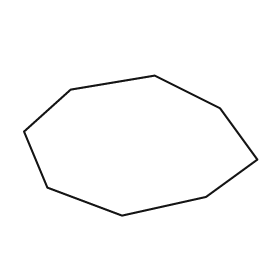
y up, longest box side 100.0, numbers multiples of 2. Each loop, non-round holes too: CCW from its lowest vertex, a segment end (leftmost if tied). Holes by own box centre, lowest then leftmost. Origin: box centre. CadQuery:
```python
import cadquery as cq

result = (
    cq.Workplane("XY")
    .moveTo(-8.0, -30.0)
    .lineTo(28.0, -22.0)
    .lineTo(50.0, -6.0)
    .lineTo(34.0, 16.0)
    .lineTo(6.0, 30.0)
    .lineTo(-30.0, 24.0)
    .lineTo(-50.0, 6.0)
    .lineTo(-40.0, -18.0)
    .close()
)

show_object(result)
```